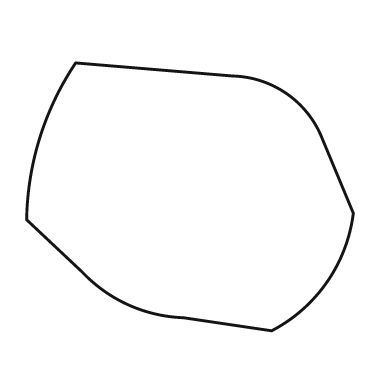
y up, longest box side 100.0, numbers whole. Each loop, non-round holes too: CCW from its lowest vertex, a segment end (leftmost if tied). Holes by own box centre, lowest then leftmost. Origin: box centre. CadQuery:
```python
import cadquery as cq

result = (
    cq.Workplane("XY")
    .moveTo(25.0, -41.0)
    .threePointArc((42.0, -26.0), (50.0, -5.0))
    .lineTo(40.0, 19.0)
    .threePointArc((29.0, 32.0), (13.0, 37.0))
    .lineTo(-35.0, 41.0)
    .threePointArc((-46.0, 18.0), (-50.0, -7.0))
    .lineTo(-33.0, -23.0)
    .threePointArc((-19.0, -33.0), (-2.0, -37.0))
    .close()
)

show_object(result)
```